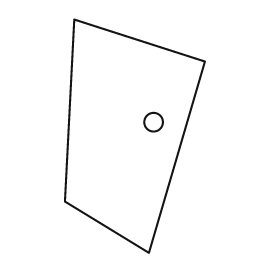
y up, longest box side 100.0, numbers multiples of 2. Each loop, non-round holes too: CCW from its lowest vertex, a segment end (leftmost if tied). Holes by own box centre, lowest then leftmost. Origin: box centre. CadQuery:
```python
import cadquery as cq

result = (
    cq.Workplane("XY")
    .moveTo(6.0, -50.0)
    .lineTo(30.0, 32.0)
    .lineTo(-26.0, 50.0)
    .lineTo(-30.0, -28.0)
    .close()
    .moveTo(8.0, 6.0)
    .circle(4.0)
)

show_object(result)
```